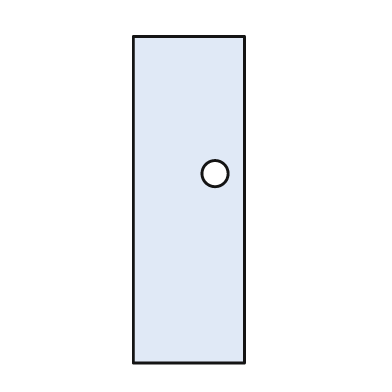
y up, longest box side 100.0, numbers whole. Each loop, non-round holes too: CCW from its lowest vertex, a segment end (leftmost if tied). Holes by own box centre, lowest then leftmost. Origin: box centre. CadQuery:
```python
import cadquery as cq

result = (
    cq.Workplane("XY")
    .moveTo(-17.0, -50.0)
    .lineTo(17.0, -50.0)
    .lineTo(17.0, 50.0)
    .lineTo(-17.0, 50.0)
    .close()
    .moveTo(8.0, 8.0)
    .circle(4.0)
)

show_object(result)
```